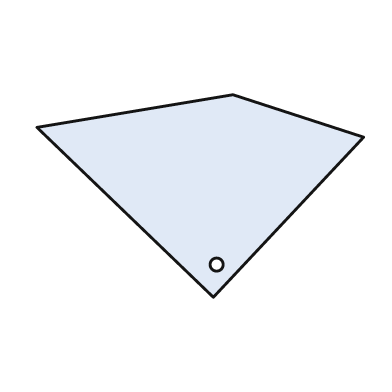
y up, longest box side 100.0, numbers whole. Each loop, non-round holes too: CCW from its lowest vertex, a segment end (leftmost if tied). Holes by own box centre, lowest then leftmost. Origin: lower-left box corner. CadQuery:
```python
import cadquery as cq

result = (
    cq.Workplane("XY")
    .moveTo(54.0, 0.0)
    .lineTo(100.0, 49.0)
    .lineTo(60.0, 62.0)
    .lineTo(0.0, 52.0)
    .close()
    .moveTo(55.0, 10.0)
    .circle(2.0)
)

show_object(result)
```